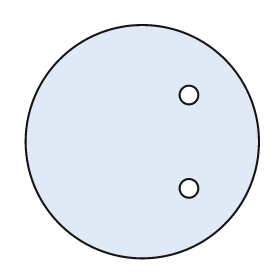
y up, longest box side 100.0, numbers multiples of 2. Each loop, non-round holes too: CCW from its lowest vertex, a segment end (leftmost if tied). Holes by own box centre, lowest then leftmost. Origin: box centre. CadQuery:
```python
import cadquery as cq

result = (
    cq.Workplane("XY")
    .moveTo(0.0, 0.0)
    .circle(50.0)
    .moveTo(20.0, -20.0)
    .circle(4.0)
    .moveTo(20.0, 20.0)
    .circle(4.0)
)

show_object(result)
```